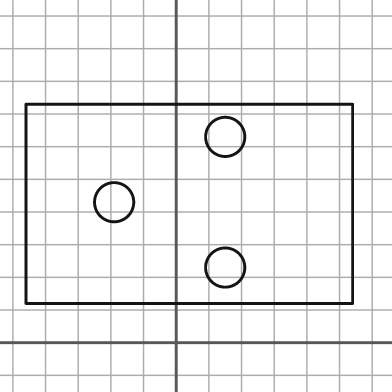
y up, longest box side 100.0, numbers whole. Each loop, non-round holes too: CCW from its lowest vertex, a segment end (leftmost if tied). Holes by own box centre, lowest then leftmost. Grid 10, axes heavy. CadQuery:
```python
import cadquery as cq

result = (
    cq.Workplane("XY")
    .moveTo(-46.0, 12.0)
    .lineTo(54.0, 12.0)
    .lineTo(54.0, 73.0)
    .lineTo(-46.0, 73.0)
    .close()
    .moveTo(15.0, 23.0)
    .circle(6.0)
    .moveTo(-19.0, 43.0)
    .circle(6.0)
    .moveTo(15.0, 63.0)
    .circle(6.0)
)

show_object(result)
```